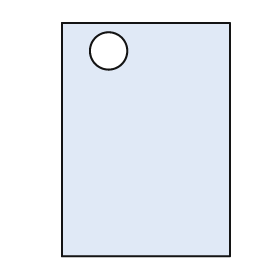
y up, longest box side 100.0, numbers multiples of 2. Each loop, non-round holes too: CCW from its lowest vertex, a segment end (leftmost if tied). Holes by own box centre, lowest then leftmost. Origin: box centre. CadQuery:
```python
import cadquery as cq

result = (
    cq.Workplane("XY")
    .moveTo(-36.0, -50.0)
    .lineTo(36.0, -50.0)
    .lineTo(36.0, 50.0)
    .lineTo(-36.0, 50.0)
    .close()
    .moveTo(-16.0, 38.0)
    .circle(8.0)
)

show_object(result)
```